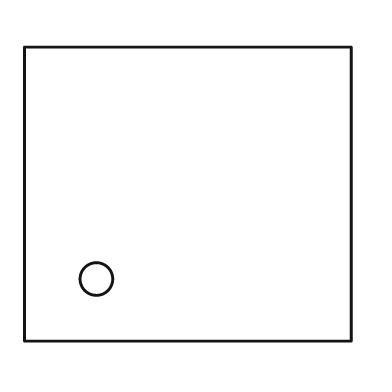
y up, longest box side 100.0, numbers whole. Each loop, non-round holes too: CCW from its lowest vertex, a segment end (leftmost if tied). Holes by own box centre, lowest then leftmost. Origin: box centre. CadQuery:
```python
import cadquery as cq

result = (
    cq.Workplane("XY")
    .moveTo(-50.0, -45.0)
    .lineTo(50.0, -45.0)
    .lineTo(50.0, 45.0)
    .lineTo(-50.0, 45.0)
    .close()
    .moveTo(-28.0, -26.0)
    .circle(5.0)
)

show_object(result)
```